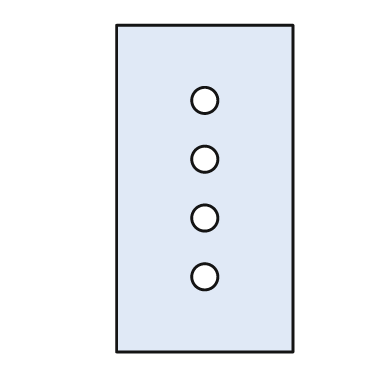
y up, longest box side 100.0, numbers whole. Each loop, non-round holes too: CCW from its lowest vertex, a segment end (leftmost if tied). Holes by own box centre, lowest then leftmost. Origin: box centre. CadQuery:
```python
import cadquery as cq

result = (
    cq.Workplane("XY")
    .moveTo(-27.0, -50.0)
    .lineTo(27.0, -50.0)
    .lineTo(27.0, 50.0)
    .lineTo(-27.0, 50.0)
    .close()
    .moveTo(0.0, -27.0)
    .circle(4.0)
    .moveTo(0.0, -9.0)
    .circle(4.0)
    .moveTo(0.0, 9.0)
    .circle(4.0)
    .moveTo(0.0, 27.0)
    .circle(4.0)
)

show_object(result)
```